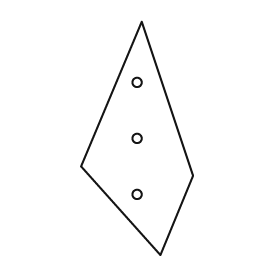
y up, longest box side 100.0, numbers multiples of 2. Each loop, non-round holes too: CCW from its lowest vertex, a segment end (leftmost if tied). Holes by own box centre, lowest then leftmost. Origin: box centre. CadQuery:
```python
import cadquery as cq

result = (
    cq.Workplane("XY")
    .moveTo(10.0, -50.0)
    .lineTo(24.0, -16.0)
    .lineTo(2.0, 50.0)
    .lineTo(-24.0, -12.0)
    .close()
    .moveTo(0.0, -24.0)
    .circle(2.0)
    .moveTo(0.0, 0.0)
    .circle(2.0)
    .moveTo(0.0, 24.0)
    .circle(2.0)
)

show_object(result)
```